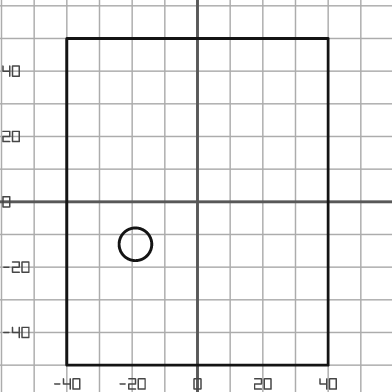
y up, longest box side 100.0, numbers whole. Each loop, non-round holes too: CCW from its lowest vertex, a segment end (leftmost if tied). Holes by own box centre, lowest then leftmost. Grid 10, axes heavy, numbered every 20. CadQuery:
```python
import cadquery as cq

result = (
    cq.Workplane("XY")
    .moveTo(-40.0, -50.0)
    .lineTo(40.0, -50.0)
    .lineTo(40.0, 50.0)
    .lineTo(-40.0, 50.0)
    .close()
    .moveTo(-19.0, -13.0)
    .circle(5.0)
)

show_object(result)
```